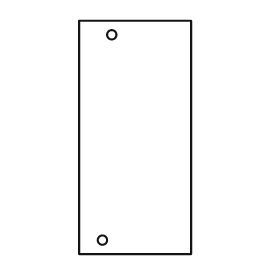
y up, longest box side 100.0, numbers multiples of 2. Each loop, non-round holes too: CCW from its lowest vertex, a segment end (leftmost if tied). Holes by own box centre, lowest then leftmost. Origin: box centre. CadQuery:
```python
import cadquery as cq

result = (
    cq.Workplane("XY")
    .moveTo(-24.0, -50.0)
    .lineTo(24.0, -50.0)
    .lineTo(24.0, 50.0)
    .lineTo(-24.0, 50.0)
    .close()
    .moveTo(-14.0, -44.0)
    .circle(2.0)
    .moveTo(-10.0, 44.0)
    .circle(2.0)
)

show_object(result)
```